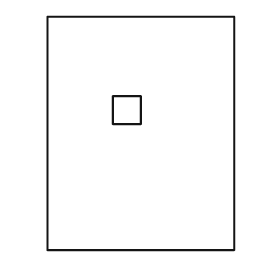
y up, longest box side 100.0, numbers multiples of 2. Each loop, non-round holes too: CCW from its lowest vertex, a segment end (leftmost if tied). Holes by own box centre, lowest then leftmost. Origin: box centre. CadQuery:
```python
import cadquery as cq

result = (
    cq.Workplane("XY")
    .moveTo(-40.0, -50.0)
    .lineTo(40.0, -50.0)
    .lineTo(40.0, 50.0)
    .lineTo(-40.0, 50.0)
    .close()
    .moveTo(-12.0, 4.0)
    .lineTo(0.0, 4.0)
    .lineTo(0.0, 16.0)
    .lineTo(-12.0, 16.0)
    .close()
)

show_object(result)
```